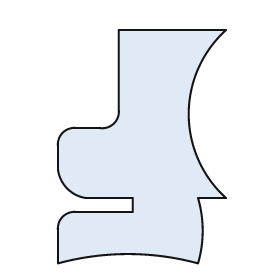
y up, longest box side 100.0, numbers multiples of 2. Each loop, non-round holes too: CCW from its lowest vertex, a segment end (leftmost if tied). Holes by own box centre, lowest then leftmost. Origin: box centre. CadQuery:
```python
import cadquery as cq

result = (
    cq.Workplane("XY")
    .moveTo(-36.0, -50.0)
    .threePointArc((-6.0, -46.0), (24.0, -50.0))
    .threePointArc((26.0, -36.0), (24.0, -22.0))
    .lineTo(36.0, -22.0)
    .threePointArc((20.0, 14.0), (36.0, 50.0))
    .lineTo(-10.0, 50.0)
    .lineTo(-10.0, 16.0)
    .threePointArc((-12.0, 10.0), (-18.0, 8.0))
    .lineTo(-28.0, 8.0)
    .threePointArc((-34.0, 6.0), (-36.0, 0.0))
    .lineTo(-36.0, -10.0)
    .threePointArc((-32.0, -18.0), (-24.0, -22.0))
    .lineTo(-4.0, -22.0)
    .lineTo(-4.0, -28.0)
    .lineTo(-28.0, -28.0)
    .threePointArc((-34.0, -30.0), (-36.0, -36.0))
    .close()
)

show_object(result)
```